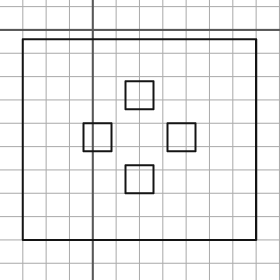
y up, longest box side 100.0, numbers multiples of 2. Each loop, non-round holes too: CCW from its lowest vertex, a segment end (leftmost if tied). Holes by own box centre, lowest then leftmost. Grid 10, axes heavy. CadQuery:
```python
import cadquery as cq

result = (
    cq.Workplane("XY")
    .moveTo(-30.0, -90.0)
    .lineTo(70.0, -90.0)
    .lineTo(70.0, -4.0)
    .lineTo(-30.0, -4.0)
    .close()
    .moveTo(14.0, -70.0)
    .lineTo(26.0, -70.0)
    .lineTo(26.0, -58.0)
    .lineTo(14.0, -58.0)
    .close()
    .moveTo(-4.0, -52.0)
    .lineTo(8.0, -52.0)
    .lineTo(8.0, -40.0)
    .lineTo(-4.0, -40.0)
    .close()
    .moveTo(32.0, -52.0)
    .lineTo(44.0, -52.0)
    .lineTo(44.0, -40.0)
    .lineTo(32.0, -40.0)
    .close()
    .moveTo(14.0, -34.0)
    .lineTo(26.0, -34.0)
    .lineTo(26.0, -22.0)
    .lineTo(14.0, -22.0)
    .close()
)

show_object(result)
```